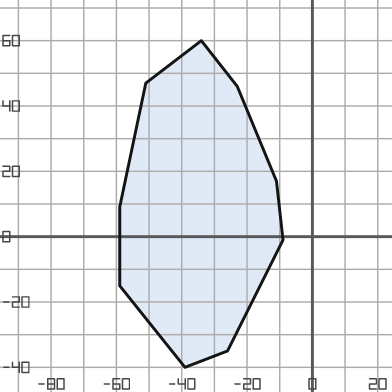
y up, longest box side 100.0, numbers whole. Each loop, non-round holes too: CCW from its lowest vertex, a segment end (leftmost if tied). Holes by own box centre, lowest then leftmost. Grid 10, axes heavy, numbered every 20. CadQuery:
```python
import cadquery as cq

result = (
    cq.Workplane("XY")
    .moveTo(-39.0, -40.0)
    .lineTo(-26.0, -35.0)
    .lineTo(-9.0, -1.0)
    .lineTo(-11.0, 17.0)
    .lineTo(-23.0, 46.0)
    .lineTo(-34.0, 60.0)
    .lineTo(-51.0, 47.0)
    .lineTo(-59.0, 9.0)
    .lineTo(-59.0, -15.0)
    .close()
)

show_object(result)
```